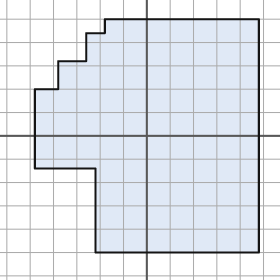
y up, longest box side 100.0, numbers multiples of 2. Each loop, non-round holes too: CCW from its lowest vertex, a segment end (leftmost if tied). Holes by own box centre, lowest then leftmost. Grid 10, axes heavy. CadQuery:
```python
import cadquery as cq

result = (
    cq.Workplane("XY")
    .moveTo(-22.0, -50.0)
    .lineTo(48.0, -50.0)
    .lineTo(48.0, 50.0)
    .lineTo(-18.0, 50.0)
    .lineTo(-18.0, 44.0)
    .lineTo(-26.0, 44.0)
    .lineTo(-26.0, 32.0)
    .lineTo(-38.0, 32.0)
    .lineTo(-38.0, 20.0)
    .lineTo(-48.0, 20.0)
    .lineTo(-48.0, -14.0)
    .lineTo(-22.0, -14.0)
    .close()
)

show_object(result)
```